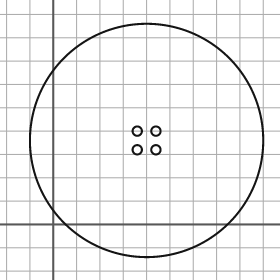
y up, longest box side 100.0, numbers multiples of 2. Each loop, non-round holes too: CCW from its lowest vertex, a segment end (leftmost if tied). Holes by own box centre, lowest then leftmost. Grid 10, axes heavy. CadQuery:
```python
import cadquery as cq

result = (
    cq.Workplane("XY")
    .moveTo(40.0, 36.0)
    .circle(50.0)
    .moveTo(36.0, 32.0)
    .circle(2.0)
    .moveTo(44.0, 32.0)
    .circle(2.0)
    .moveTo(36.0, 40.0)
    .circle(2.0)
    .moveTo(44.0, 40.0)
    .circle(2.0)
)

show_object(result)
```